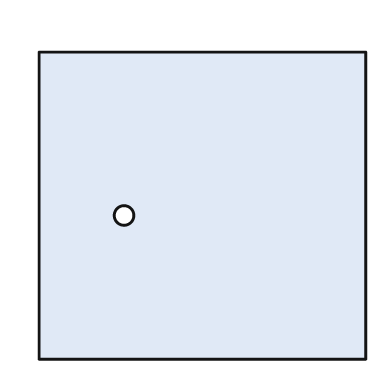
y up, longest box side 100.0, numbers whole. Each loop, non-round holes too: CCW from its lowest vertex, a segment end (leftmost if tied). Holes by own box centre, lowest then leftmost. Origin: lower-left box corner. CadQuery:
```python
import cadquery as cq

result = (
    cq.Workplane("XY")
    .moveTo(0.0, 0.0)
    .lineTo(100.0, 0.0)
    .lineTo(100.0, 94.0)
    .lineTo(0.0, 94.0)
    .close()
    .moveTo(26.0, 44.0)
    .circle(3.0)
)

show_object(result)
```